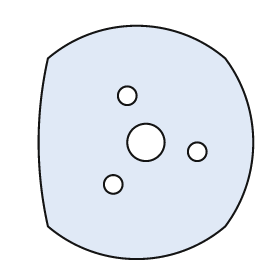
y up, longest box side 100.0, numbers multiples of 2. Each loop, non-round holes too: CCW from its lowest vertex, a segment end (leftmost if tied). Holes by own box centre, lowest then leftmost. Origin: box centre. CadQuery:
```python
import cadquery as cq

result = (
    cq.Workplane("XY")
    .moveTo(-42.0, -36.0)
    .threePointArc((-4.0, -50.0), (34.0, -36.0))
    .threePointArc((46.0, 0.0), (34.0, 36.0))
    .threePointArc((-4.0, 50.0), (-42.0, 36.0))
    .threePointArc((-46.0, 0.0), (-42.0, -36.0))
    .close()
    .moveTo(-14.0, -18.0)
    .circle(4.0)
    .moveTo(22.0, -4.0)
    .circle(4.0)
    .moveTo(0.0, 0.0)
    .circle(8.0)
    .moveTo(-8.0, 20.0)
    .circle(4.0)
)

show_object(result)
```